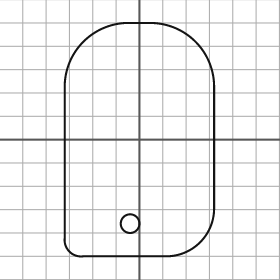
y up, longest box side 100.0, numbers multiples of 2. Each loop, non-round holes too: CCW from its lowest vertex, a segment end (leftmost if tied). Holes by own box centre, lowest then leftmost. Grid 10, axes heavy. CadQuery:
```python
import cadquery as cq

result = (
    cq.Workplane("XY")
    .moveTo(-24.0, -50.0)
    .lineTo(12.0, -50.0)
    .threePointArc((26.0, -44.0), (32.0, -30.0))
    .lineTo(32.0, 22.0)
    .threePointArc((24.0, 42.0), (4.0, 50.0))
    .lineTo(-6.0, 50.0)
    .threePointArc((-24.0, 42.0), (-32.0, 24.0))
    .lineTo(-32.0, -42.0)
    .threePointArc((-30.0, -48.0), (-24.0, -50.0))
    .close()
    .moveTo(-4.0, -36.0)
    .circle(4.0)
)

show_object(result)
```